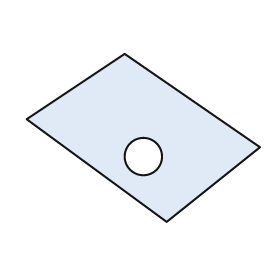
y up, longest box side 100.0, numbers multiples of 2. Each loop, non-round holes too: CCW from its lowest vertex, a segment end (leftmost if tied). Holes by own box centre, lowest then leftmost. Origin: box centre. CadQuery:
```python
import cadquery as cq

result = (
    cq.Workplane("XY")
    .moveTo(10.0, -36.0)
    .lineTo(50.0, -4.0)
    .lineTo(-8.0, 36.0)
    .lineTo(-50.0, 8.0)
    .close()
    .moveTo(0.0, -8.0)
    .circle(8.0)
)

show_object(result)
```